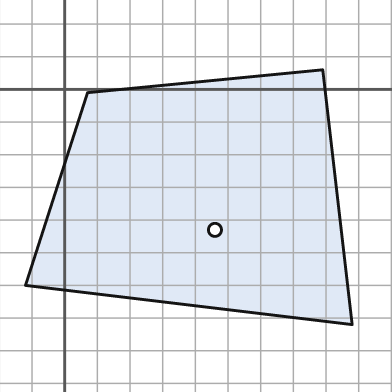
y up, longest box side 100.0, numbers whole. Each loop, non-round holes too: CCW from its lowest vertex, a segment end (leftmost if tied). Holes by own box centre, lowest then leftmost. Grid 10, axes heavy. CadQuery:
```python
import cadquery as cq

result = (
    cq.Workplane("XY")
    .moveTo(88.0, -72.0)
    .lineTo(79.0, 6.0)
    .lineTo(7.0, -1.0)
    .lineTo(-12.0, -60.0)
    .close()
    .moveTo(46.0, -43.0)
    .circle(2.0)
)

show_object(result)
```